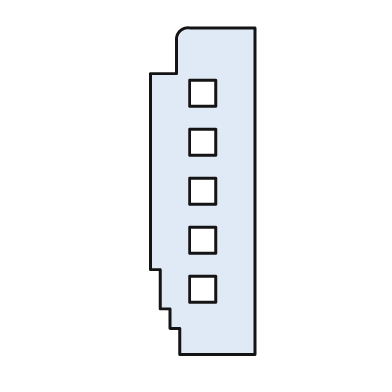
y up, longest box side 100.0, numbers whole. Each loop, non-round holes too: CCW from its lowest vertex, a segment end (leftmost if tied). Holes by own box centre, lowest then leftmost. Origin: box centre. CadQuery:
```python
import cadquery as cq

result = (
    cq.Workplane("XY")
    .moveTo(-7.0, -50.0)
    .lineTo(16.0, -50.0)
    .lineTo(16.0, 50.0)
    .lineTo(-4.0, 50.0)
    .threePointArc((-7.0, 49.0), (-8.0, 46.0))
    .lineTo(-8.0, 36.0)
    .lineTo(-16.0, 36.0)
    .lineTo(-16.0, -24.0)
    .lineTo(-13.0, -24.0)
    .lineTo(-13.0, -36.0)
    .lineTo(-10.0, -36.0)
    .lineTo(-10.0, -42.0)
    .lineTo(-7.0, -42.0)
    .close()
    .moveTo(-4.0, -34.0)
    .lineTo(4.0, -34.0)
    .lineTo(4.0, -26.0)
    .lineTo(-4.0, -26.0)
    .close()
    .moveTo(-4.0, -19.0)
    .lineTo(4.0, -19.0)
    .lineTo(4.0, -11.0)
    .lineTo(-4.0, -11.0)
    .close()
    .moveTo(-4.0, -4.0)
    .lineTo(4.0, -4.0)
    .lineTo(4.0, 4.0)
    .lineTo(-4.0, 4.0)
    .close()
    .moveTo(-4.0, 11.0)
    .lineTo(4.0, 11.0)
    .lineTo(4.0, 19.0)
    .lineTo(-4.0, 19.0)
    .close()
    .moveTo(-4.0, 26.0)
    .lineTo(4.0, 26.0)
    .lineTo(4.0, 34.0)
    .lineTo(-4.0, 34.0)
    .close()
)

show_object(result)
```